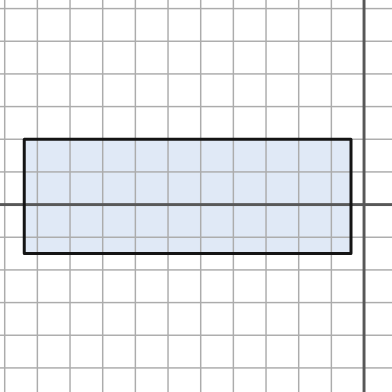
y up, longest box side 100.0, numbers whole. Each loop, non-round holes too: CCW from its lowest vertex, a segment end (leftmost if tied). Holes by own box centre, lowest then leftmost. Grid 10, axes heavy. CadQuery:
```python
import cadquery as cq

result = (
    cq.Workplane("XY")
    .moveTo(-104.0, -15.0)
    .lineTo(-4.0, -15.0)
    .lineTo(-4.0, 20.0)
    .lineTo(-104.0, 20.0)
    .close()
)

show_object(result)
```